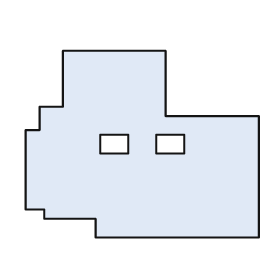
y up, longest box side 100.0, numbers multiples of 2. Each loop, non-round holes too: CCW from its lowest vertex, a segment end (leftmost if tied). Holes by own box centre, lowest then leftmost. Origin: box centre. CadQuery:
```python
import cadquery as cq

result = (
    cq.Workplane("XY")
    .moveTo(-20.0, -40.0)
    .lineTo(50.0, -40.0)
    .lineTo(50.0, 12.0)
    .lineTo(10.0, 12.0)
    .lineTo(10.0, 40.0)
    .lineTo(-34.0, 40.0)
    .lineTo(-34.0, 16.0)
    .lineTo(-44.0, 16.0)
    .lineTo(-44.0, 6.0)
    .lineTo(-50.0, 6.0)
    .lineTo(-50.0, -28.0)
    .lineTo(-42.0, -28.0)
    .lineTo(-42.0, -32.0)
    .lineTo(-20.0, -32.0)
    .close()
    .moveTo(-18.0, -4.0)
    .lineTo(-6.0, -4.0)
    .lineTo(-6.0, 4.0)
    .lineTo(-18.0, 4.0)
    .close()
    .moveTo(6.0, -4.0)
    .lineTo(18.0, -4.0)
    .lineTo(18.0, 4.0)
    .lineTo(6.0, 4.0)
    .close()
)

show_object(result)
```